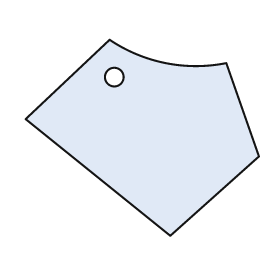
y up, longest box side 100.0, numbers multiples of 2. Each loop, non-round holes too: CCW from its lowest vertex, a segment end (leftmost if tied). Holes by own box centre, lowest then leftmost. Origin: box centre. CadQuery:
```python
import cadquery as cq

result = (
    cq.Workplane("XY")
    .moveTo(12.0, -42.0)
    .lineTo(50.0, -8.0)
    .lineTo(36.0, 32.0)
    .threePointArc((10.0, 32.0), (-14.0, 42.0))
    .lineTo(-50.0, 8.0)
    .close()
    .moveTo(-12.0, 26.0)
    .circle(4.0)
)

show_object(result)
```